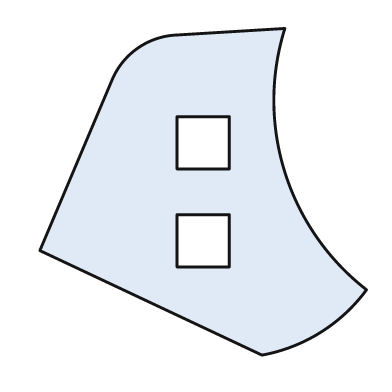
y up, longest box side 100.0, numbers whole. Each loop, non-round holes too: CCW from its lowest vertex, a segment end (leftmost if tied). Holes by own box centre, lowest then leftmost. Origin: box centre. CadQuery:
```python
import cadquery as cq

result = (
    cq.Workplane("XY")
    .moveTo(18.0, -50.0)
    .threePointArc((36.0, -43.0), (50.0, -30.0))
    .threePointArc((25.0, 6.0), (25.0, 50.0))
    .lineTo(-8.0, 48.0)
    .threePointArc((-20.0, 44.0), (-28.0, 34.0))
    .lineTo(-50.0, -18.0)
    .close()
    .moveTo(-8.0, -23.0)
    .lineTo(8.0, -23.0)
    .lineTo(8.0, -7.0)
    .lineTo(-8.0, -7.0)
    .close()
    .moveTo(-8.0, 7.0)
    .lineTo(8.0, 7.0)
    .lineTo(8.0, 23.0)
    .lineTo(-8.0, 23.0)
    .close()
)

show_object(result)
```